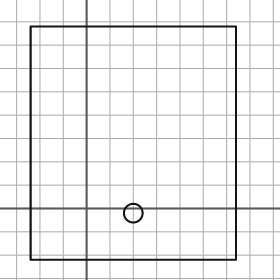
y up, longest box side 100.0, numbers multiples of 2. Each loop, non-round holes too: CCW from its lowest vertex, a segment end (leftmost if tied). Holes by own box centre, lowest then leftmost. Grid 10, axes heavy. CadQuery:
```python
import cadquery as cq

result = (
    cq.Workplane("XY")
    .moveTo(-24.0, -22.0)
    .lineTo(64.0, -22.0)
    .lineTo(64.0, 78.0)
    .lineTo(-24.0, 78.0)
    .close()
    .moveTo(20.0, -2.0)
    .circle(4.0)
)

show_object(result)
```